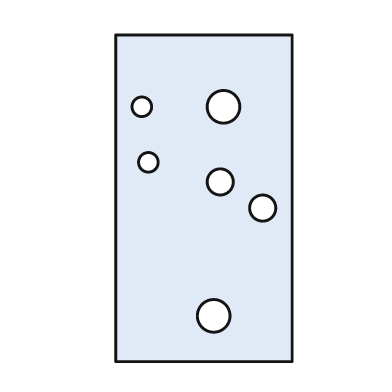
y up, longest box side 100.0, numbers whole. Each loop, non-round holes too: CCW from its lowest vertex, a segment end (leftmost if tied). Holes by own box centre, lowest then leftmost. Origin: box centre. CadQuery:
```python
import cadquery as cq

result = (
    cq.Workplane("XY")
    .moveTo(-27.0, -50.0)
    .lineTo(27.0, -50.0)
    .lineTo(27.0, 50.0)
    .lineTo(-27.0, 50.0)
    .close()
    .moveTo(3.0, -36.0)
    .circle(5.0)
    .moveTo(18.0, -3.0)
    .circle(4.0)
    .moveTo(5.0, 5.0)
    .circle(4.0)
    .moveTo(-17.0, 11.0)
    .circle(3.0)
    .moveTo(-19.0, 28.0)
    .circle(3.0)
    .moveTo(6.0, 28.0)
    .circle(5.0)
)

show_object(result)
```